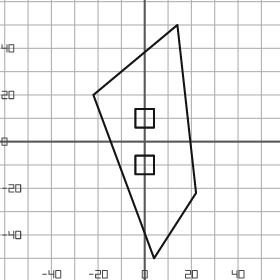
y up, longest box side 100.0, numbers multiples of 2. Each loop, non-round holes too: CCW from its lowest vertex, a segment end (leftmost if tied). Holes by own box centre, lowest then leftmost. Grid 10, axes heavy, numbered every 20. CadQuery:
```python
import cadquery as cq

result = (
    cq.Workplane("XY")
    .moveTo(4.0, -50.0)
    .lineTo(22.0, -22.0)
    .lineTo(14.0, 50.0)
    .lineTo(-22.0, 20.0)
    .close()
    .moveTo(-4.0, -14.0)
    .lineTo(4.0, -14.0)
    .lineTo(4.0, -6.0)
    .lineTo(-4.0, -6.0)
    .close()
    .moveTo(-4.0, 6.0)
    .lineTo(4.0, 6.0)
    .lineTo(4.0, 14.0)
    .lineTo(-4.0, 14.0)
    .close()
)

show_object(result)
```